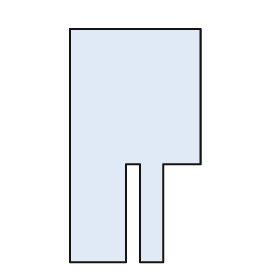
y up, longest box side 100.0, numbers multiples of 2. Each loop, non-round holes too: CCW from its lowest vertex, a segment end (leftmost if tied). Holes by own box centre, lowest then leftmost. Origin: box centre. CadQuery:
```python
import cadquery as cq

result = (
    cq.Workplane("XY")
    .moveTo(-28.0, -50.0)
    .lineTo(-4.0, -50.0)
    .lineTo(-4.0, -8.0)
    .lineTo(2.0, -8.0)
    .lineTo(2.0, -50.0)
    .lineTo(12.0, -50.0)
    .lineTo(12.0, -8.0)
    .lineTo(28.0, -8.0)
    .lineTo(28.0, 50.0)
    .lineTo(-28.0, 50.0)
    .close()
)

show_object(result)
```